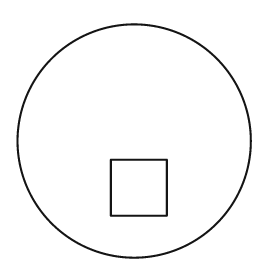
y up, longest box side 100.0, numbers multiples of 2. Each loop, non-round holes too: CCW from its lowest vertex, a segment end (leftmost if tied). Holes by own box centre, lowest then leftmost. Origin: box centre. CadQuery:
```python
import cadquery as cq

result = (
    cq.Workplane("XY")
    .moveTo(0.0, 0.0)
    .circle(50.0)
    .moveTo(-10.0, -32.0)
    .lineTo(14.0, -32.0)
    .lineTo(14.0, -8.0)
    .lineTo(-10.0, -8.0)
    .close()
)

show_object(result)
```